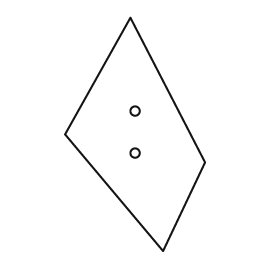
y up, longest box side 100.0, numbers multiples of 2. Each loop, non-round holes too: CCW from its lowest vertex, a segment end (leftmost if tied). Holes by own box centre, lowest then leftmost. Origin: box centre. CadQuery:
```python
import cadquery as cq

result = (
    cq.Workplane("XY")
    .moveTo(12.0, -50.0)
    .lineTo(30.0, -12.0)
    .lineTo(-2.0, 50.0)
    .lineTo(-30.0, 0.0)
    .close()
    .moveTo(0.0, -8.0)
    .circle(2.0)
    .moveTo(0.0, 10.0)
    .circle(2.0)
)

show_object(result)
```